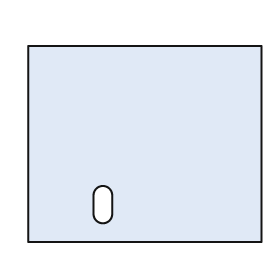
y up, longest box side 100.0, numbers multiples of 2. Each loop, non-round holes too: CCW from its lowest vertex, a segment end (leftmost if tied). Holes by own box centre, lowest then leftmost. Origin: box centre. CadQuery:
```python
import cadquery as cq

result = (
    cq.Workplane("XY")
    .moveTo(-50.0, -42.0)
    .lineTo(50.0, -42.0)
    .lineTo(50.0, 42.0)
    .lineTo(-50.0, 42.0)
    .close()
    .moveTo(-22.0, -30.0)
    .threePointArc((-18.0, -34.0), (-14.0, -30.0))
    .lineTo(-14.0, -22.0)
    .threePointArc((-18.0, -18.0), (-22.0, -22.0))
    .close()
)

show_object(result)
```